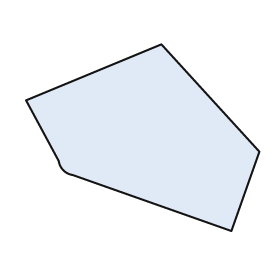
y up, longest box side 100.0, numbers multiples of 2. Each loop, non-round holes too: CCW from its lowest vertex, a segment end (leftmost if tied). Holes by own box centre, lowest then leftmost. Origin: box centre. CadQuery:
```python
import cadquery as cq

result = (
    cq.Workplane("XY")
    .moveTo(38.0, -40.0)
    .lineTo(50.0, -6.0)
    .lineTo(8.0, 40.0)
    .lineTo(-50.0, 16.0)
    .lineTo(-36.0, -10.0)
    .threePointArc((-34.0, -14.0), (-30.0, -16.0))
    .close()
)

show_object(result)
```